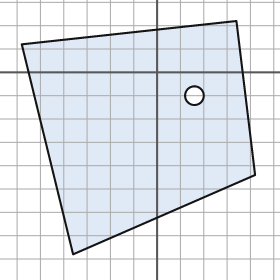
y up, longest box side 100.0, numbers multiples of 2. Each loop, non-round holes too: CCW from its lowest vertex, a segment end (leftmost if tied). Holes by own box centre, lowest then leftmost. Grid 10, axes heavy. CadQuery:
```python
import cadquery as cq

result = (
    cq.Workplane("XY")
    .moveTo(-36.0, -78.0)
    .lineTo(42.0, -44.0)
    .lineTo(34.0, 22.0)
    .lineTo(-58.0, 12.0)
    .close()
    .moveTo(16.0, -10.0)
    .circle(4.0)
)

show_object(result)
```